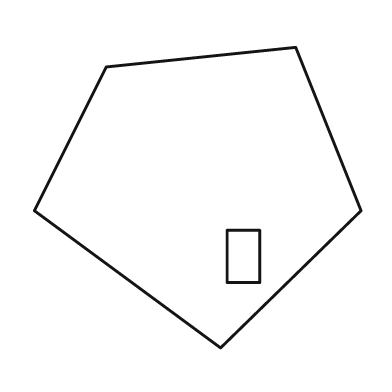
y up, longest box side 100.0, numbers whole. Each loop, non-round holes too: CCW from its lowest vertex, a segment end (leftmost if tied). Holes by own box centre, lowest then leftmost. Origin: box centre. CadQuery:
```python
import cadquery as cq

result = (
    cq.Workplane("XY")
    .moveTo(7.0, -46.0)
    .lineTo(50.0, -4.0)
    .lineTo(30.0, 46.0)
    .lineTo(-28.0, 40.0)
    .lineTo(-50.0, -4.0)
    .close()
    .moveTo(9.0, -26.0)
    .lineTo(19.0, -26.0)
    .lineTo(19.0, -10.0)
    .lineTo(9.0, -10.0)
    .close()
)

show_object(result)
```